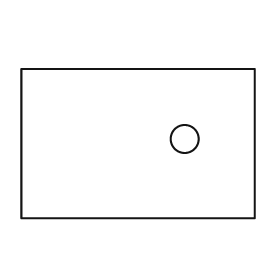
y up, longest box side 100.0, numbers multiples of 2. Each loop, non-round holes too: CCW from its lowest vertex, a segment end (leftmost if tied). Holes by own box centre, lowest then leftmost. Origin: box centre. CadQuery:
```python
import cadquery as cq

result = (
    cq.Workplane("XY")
    .moveTo(-50.0, -32.0)
    .lineTo(50.0, -32.0)
    .lineTo(50.0, 32.0)
    .lineTo(-50.0, 32.0)
    .close()
    .moveTo(20.0, 2.0)
    .circle(6.0)
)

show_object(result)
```